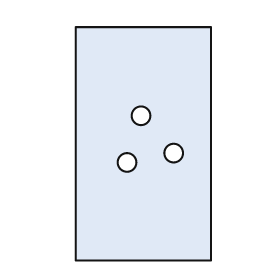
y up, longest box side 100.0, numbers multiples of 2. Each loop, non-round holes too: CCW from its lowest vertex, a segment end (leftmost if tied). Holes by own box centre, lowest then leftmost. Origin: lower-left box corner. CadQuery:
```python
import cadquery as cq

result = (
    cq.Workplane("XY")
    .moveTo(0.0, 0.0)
    .lineTo(58.0, 0.0)
    .lineTo(58.0, 100.0)
    .lineTo(0.0, 100.0)
    .close()
    .moveTo(22.0, 42.0)
    .circle(4.0)
    .moveTo(42.0, 46.0)
    .circle(4.0)
    .moveTo(28.0, 62.0)
    .circle(4.0)
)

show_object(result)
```